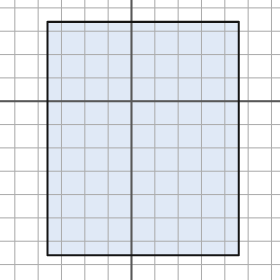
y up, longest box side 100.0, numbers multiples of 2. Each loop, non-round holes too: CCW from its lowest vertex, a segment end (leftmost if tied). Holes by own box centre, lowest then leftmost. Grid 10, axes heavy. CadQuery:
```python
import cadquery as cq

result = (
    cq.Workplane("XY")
    .moveTo(-36.0, -66.0)
    .lineTo(46.0, -66.0)
    .lineTo(46.0, 34.0)
    .lineTo(-36.0, 34.0)
    .close()
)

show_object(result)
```